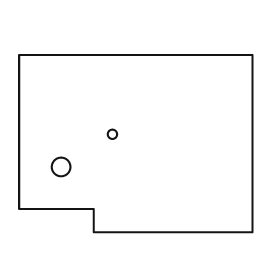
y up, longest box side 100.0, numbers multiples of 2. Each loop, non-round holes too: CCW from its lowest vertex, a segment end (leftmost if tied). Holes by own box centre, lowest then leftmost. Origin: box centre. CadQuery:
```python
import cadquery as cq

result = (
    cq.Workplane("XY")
    .moveTo(-18.0, -38.0)
    .lineTo(50.0, -38.0)
    .lineTo(50.0, 38.0)
    .lineTo(-50.0, 38.0)
    .lineTo(-50.0, -28.0)
    .lineTo(-18.0, -28.0)
    .close()
    .moveTo(-32.0, -10.0)
    .circle(4.0)
    .moveTo(-10.0, 4.0)
    .circle(2.0)
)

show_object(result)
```